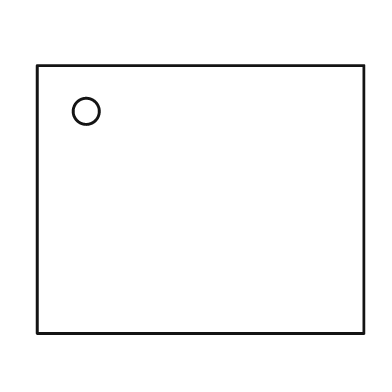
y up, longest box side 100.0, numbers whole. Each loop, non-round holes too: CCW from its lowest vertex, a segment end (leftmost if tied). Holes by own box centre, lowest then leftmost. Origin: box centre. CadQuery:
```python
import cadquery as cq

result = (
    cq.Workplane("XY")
    .moveTo(-50.0, -41.0)
    .lineTo(50.0, -41.0)
    .lineTo(50.0, 41.0)
    .lineTo(-50.0, 41.0)
    .close()
    .moveTo(-35.0, 27.0)
    .circle(4.0)
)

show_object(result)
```